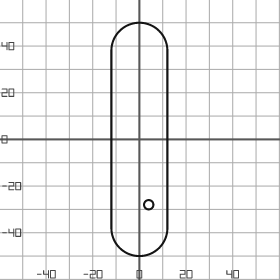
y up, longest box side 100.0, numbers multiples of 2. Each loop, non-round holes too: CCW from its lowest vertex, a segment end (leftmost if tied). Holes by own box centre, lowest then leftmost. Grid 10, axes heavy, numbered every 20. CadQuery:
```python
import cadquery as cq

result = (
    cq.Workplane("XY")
    .moveTo(-12.0, -38.0)
    .threePointArc((0.0, -50.0), (12.0, -38.0))
    .lineTo(12.0, 38.0)
    .threePointArc((0.0, 50.0), (-12.0, 38.0))
    .close()
    .moveTo(4.0, -28.0)
    .circle(2.0)
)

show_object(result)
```